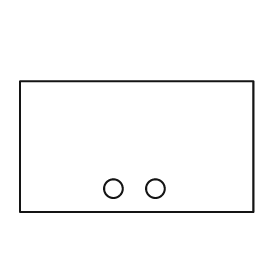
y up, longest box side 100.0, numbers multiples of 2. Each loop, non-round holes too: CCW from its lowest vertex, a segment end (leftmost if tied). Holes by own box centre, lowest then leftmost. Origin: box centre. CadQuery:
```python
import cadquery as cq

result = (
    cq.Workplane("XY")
    .moveTo(-50.0, -28.0)
    .lineTo(50.0, -28.0)
    .lineTo(50.0, 28.0)
    .lineTo(-50.0, 28.0)
    .close()
    .moveTo(-10.0, -18.0)
    .circle(4.0)
    .moveTo(8.0, -18.0)
    .circle(4.0)
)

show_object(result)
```